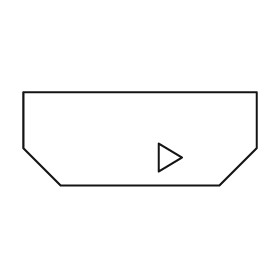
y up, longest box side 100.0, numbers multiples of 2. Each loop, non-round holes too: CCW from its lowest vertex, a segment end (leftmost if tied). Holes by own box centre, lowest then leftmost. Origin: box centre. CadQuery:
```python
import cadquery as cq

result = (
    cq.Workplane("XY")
    .moveTo(-34.0, -20.0)
    .lineTo(34.0, -20.0)
    .lineTo(50.0, -4.0)
    .lineTo(50.0, 20.0)
    .lineTo(-50.0, 20.0)
    .lineTo(-50.0, -4.0)
    .close()
    .moveTo(8.0, -14.0)
    .lineTo(18.0, -8.0)
    .lineTo(8.0, -2.0)
    .close()
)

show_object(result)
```